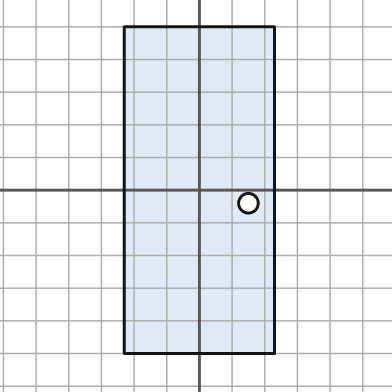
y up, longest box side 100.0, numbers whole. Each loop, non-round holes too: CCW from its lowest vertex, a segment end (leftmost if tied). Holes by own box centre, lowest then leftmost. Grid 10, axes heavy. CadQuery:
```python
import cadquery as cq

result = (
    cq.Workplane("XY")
    .moveTo(-23.0, -50.0)
    .lineTo(23.0, -50.0)
    .lineTo(23.0, 50.0)
    .lineTo(-23.0, 50.0)
    .close()
    .moveTo(15.0, -4.0)
    .circle(3.0)
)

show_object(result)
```